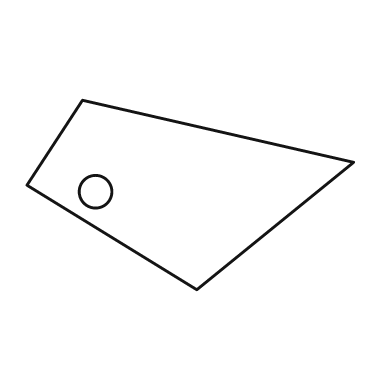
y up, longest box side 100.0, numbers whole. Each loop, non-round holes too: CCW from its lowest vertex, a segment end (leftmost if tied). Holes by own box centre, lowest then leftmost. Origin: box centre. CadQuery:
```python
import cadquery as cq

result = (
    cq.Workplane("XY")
    .moveTo(2.0, -29.0)
    .lineTo(50.0, 10.0)
    .lineTo(-33.0, 29.0)
    .lineTo(-50.0, 3.0)
    .close()
    .moveTo(-29.0, 1.0)
    .circle(5.0)
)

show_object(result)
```